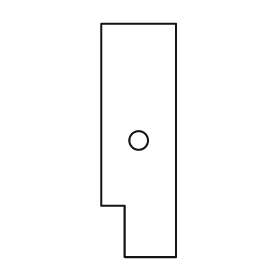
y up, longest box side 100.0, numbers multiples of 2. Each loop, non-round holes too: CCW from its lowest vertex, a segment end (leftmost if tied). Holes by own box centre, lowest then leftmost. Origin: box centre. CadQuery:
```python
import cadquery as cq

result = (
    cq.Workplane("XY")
    .moveTo(-6.0, -50.0)
    .lineTo(16.0, -50.0)
    .lineTo(16.0, 50.0)
    .lineTo(-16.0, 50.0)
    .lineTo(-16.0, -28.0)
    .lineTo(-6.0, -28.0)
    .close()
    .moveTo(0.0, 0.0)
    .circle(4.0)
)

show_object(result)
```